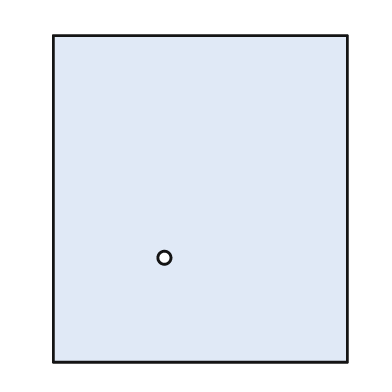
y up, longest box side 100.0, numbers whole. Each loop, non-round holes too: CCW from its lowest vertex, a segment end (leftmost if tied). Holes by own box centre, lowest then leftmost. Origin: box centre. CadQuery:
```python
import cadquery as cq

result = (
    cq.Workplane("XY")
    .moveTo(-45.0, -50.0)
    .lineTo(45.0, -50.0)
    .lineTo(45.0, 50.0)
    .lineTo(-45.0, 50.0)
    .close()
    .moveTo(-11.0, -18.0)
    .circle(2.0)
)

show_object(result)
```